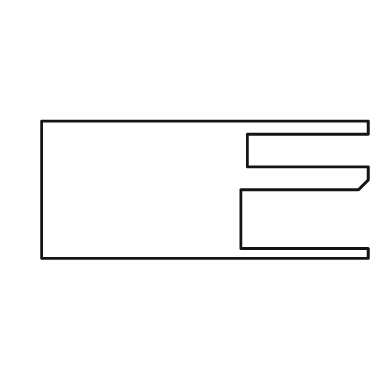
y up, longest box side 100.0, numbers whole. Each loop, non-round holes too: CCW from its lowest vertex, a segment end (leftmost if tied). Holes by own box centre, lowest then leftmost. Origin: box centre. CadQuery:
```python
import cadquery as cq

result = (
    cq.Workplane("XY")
    .moveTo(-50.0, -21.0)
    .lineTo(50.0, -21.0)
    .lineTo(50.0, -18.0)
    .lineTo(11.0, -18.0)
    .lineTo(11.0, 0.0)
    .lineTo(47.0, 0.0)
    .lineTo(50.0, 3.0)
    .lineTo(50.0, 7.0)
    .lineTo(13.0, 7.0)
    .lineTo(13.0, 17.0)
    .lineTo(50.0, 17.0)
    .lineTo(50.0, 21.0)
    .lineTo(-50.0, 21.0)
    .close()
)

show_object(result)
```